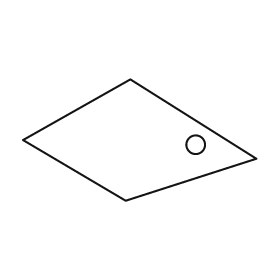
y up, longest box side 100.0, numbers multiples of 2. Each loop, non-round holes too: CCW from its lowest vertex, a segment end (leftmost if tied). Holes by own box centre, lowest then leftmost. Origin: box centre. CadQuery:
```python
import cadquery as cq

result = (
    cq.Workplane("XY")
    .moveTo(-6.0, -26.0)
    .lineTo(50.0, -8.0)
    .lineTo(-4.0, 26.0)
    .lineTo(-50.0, 0.0)
    .close()
    .moveTo(24.0, -2.0)
    .circle(4.0)
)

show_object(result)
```